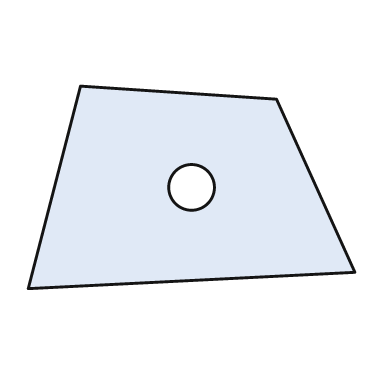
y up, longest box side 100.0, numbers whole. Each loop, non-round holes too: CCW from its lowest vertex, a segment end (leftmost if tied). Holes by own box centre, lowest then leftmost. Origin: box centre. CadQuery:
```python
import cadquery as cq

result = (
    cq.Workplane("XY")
    .moveTo(-50.0, -31.0)
    .lineTo(50.0, -26.0)
    .lineTo(26.0, 27.0)
    .lineTo(-34.0, 31.0)
    .close()
    .moveTo(0.0, 0.0)
    .circle(7.0)
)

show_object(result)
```